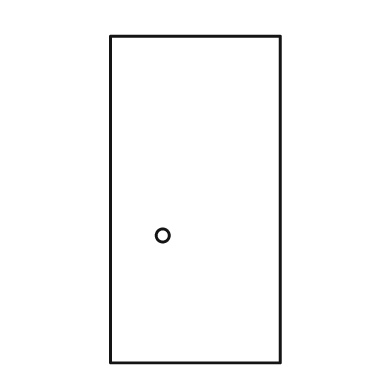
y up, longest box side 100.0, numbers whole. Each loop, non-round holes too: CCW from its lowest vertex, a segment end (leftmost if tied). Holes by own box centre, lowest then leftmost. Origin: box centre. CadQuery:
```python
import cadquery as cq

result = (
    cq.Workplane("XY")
    .moveTo(-26.0, -50.0)
    .lineTo(26.0, -50.0)
    .lineTo(26.0, 50.0)
    .lineTo(-26.0, 50.0)
    .close()
    .moveTo(-10.0, -11.0)
    .circle(2.0)
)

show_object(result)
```